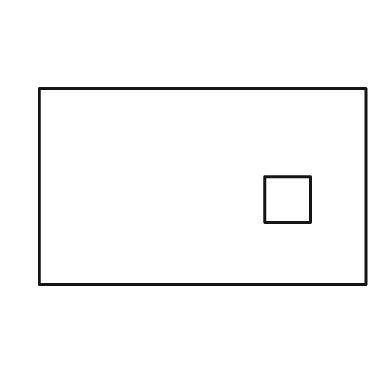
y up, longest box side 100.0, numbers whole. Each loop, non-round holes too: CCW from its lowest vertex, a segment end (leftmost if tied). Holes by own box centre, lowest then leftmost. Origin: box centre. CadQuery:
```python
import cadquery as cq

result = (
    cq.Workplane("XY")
    .moveTo(-50.0, -30.0)
    .lineTo(50.0, -30.0)
    .lineTo(50.0, 30.0)
    .lineTo(-50.0, 30.0)
    .close()
    .moveTo(19.0, -11.0)
    .lineTo(33.0, -11.0)
    .lineTo(33.0, 3.0)
    .lineTo(19.0, 3.0)
    .close()
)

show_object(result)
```